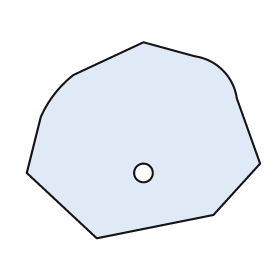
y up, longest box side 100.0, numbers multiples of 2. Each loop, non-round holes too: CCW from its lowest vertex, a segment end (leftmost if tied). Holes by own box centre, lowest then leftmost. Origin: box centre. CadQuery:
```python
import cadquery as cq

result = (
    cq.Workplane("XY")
    .moveTo(-20.0, -42.0)
    .lineTo(30.0, -32.0)
    .lineTo(50.0, -10.0)
    .lineTo(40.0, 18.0)
    .threePointArc((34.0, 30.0), (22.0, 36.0))
    .lineTo(0.0, 42.0)
    .lineTo(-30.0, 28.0)
    .threePointArc((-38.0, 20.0), (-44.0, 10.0))
    .lineTo(-50.0, -14.0)
    .close()
    .moveTo(0.0, -14.0)
    .circle(4.0)
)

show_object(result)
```